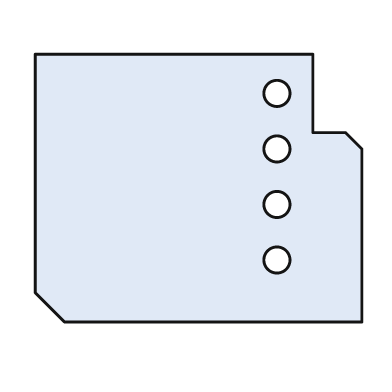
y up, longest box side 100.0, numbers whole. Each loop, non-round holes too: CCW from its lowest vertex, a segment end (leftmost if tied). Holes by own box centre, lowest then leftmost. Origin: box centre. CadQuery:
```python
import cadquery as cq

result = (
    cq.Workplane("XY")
    .moveTo(-41.0, -41.0)
    .lineTo(50.0, -41.0)
    .lineTo(50.0, 12.0)
    .lineTo(45.0, 17.0)
    .lineTo(35.0, 17.0)
    .lineTo(35.0, 41.0)
    .lineTo(-50.0, 41.0)
    .lineTo(-50.0, -32.0)
    .close()
    .moveTo(24.0, -22.0)
    .circle(4.0)
    .moveTo(24.0, -5.0)
    .circle(4.0)
    .moveTo(24.0, 12.0)
    .circle(4.0)
    .moveTo(24.0, 29.0)
    .circle(4.0)
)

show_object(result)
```